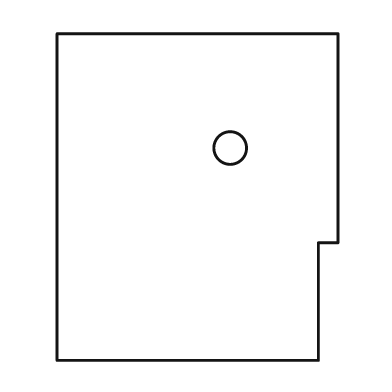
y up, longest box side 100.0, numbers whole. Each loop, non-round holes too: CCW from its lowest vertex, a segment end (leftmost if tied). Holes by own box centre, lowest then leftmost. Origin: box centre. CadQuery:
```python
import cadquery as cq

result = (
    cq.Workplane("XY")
    .moveTo(-43.0, -50.0)
    .lineTo(37.0, -50.0)
    .lineTo(37.0, -14.0)
    .lineTo(43.0, -14.0)
    .lineTo(43.0, 50.0)
    .lineTo(-43.0, 50.0)
    .close()
    .moveTo(10.0, 15.0)
    .circle(5.0)
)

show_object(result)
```